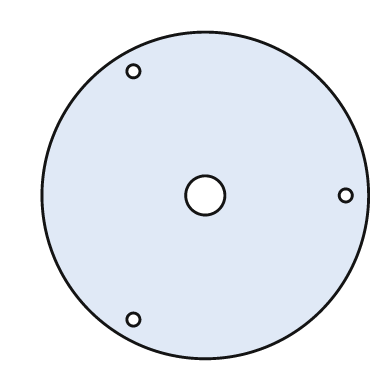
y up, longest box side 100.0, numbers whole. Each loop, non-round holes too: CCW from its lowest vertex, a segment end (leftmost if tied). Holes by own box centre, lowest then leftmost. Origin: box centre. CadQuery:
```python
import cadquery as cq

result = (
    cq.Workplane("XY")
    .moveTo(0.0, 0.0)
    .circle(50.0)
    .moveTo(-22.0, -38.0)
    .circle(2.0)
    .moveTo(0.0, 0.0)
    .circle(6.0)
    .moveTo(43.0, 0.0)
    .circle(2.0)
    .moveTo(-22.0, 38.0)
    .circle(2.0)
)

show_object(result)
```